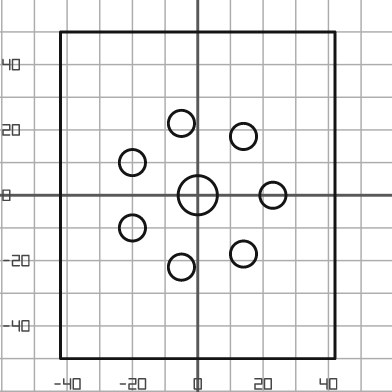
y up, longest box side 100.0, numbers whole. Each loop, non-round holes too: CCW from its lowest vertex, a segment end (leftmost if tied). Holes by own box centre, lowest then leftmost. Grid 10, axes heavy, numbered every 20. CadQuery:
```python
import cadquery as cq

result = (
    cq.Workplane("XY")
    .moveTo(-42.0, -50.0)
    .lineTo(42.0, -50.0)
    .lineTo(42.0, 50.0)
    .lineTo(-42.0, 50.0)
    .close()
    .moveTo(-5.0, -22.0)
    .circle(4.0)
    .moveTo(14.0, -18.0)
    .circle(4.0)
    .moveTo(-20.0, -10.0)
    .circle(4.0)
    .moveTo(0.0, 0.0)
    .circle(6.0)
    .moveTo(23.0, 0.0)
    .circle(4.0)
    .moveTo(-20.0, 10.0)
    .circle(4.0)
    .moveTo(14.0, 18.0)
    .circle(4.0)
    .moveTo(-5.0, 22.0)
    .circle(4.0)
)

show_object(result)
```